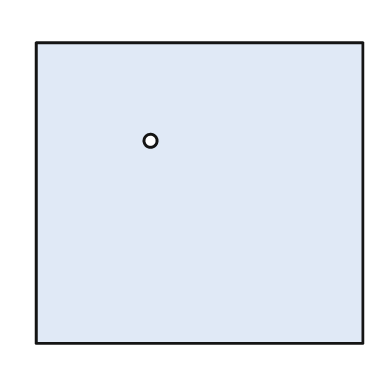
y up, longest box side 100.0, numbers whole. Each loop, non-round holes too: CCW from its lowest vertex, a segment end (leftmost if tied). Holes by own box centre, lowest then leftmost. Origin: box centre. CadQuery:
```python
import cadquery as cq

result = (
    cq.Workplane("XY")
    .moveTo(-50.0, -46.0)
    .lineTo(50.0, -46.0)
    .lineTo(50.0, 46.0)
    .lineTo(-50.0, 46.0)
    .close()
    .moveTo(-15.0, 16.0)
    .circle(2.0)
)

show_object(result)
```